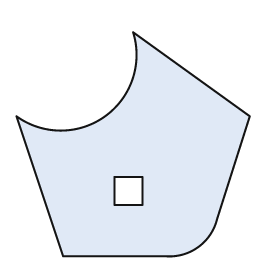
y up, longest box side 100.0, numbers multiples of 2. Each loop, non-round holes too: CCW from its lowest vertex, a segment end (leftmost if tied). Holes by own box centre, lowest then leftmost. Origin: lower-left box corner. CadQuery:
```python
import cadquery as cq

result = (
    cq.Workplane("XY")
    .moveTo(20.0, 0.0)
    .lineTo(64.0, 0.0)
    .threePointArc((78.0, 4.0), (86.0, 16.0))
    .lineTo(100.0, 60.0)
    .lineTo(50.0, 96.0)
    .threePointArc((38.0, 60.0), (0.0, 60.0))
    .close()
    .moveTo(42.0, 22.0)
    .lineTo(54.0, 22.0)
    .lineTo(54.0, 34.0)
    .lineTo(42.0, 34.0)
    .close()
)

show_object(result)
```